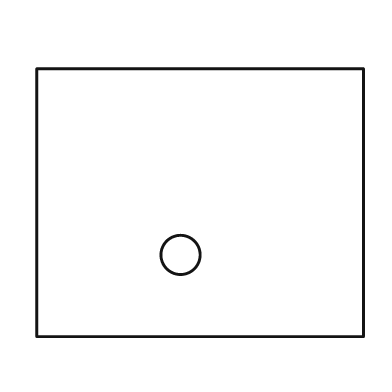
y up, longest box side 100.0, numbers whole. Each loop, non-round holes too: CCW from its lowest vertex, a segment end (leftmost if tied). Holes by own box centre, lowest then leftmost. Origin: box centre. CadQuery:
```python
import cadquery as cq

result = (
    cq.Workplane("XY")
    .moveTo(-50.0, -41.0)
    .lineTo(50.0, -41.0)
    .lineTo(50.0, 41.0)
    .lineTo(-50.0, 41.0)
    .close()
    .moveTo(-6.0, -16.0)
    .circle(6.0)
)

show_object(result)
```